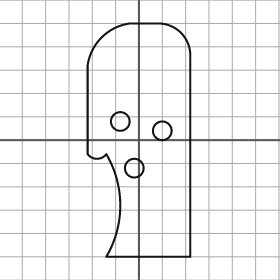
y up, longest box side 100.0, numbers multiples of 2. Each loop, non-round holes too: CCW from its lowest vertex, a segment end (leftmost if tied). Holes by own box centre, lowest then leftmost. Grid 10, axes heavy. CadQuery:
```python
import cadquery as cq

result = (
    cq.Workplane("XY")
    .moveTo(-14.0, -50.0)
    .lineTo(22.0, -50.0)
    .lineTo(22.0, 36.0)
    .threePointArc((18.0, 46.0), (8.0, 50.0))
    .lineTo(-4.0, 50.0)
    .threePointArc((-16.0, 44.0), (-22.0, 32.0))
    .lineTo(-22.0, -6.0)
    .threePointArc((-18.0, -8.0), (-14.0, -6.0))
    .threePointArc((-8.0, -28.0), (-14.0, -50.0))
    .close()
    .moveTo(-2.0, -12.0)
    .circle(4.0)
    .moveTo(10.0, 4.0)
    .circle(4.0)
    .moveTo(-8.0, 8.0)
    .circle(4.0)
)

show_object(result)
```